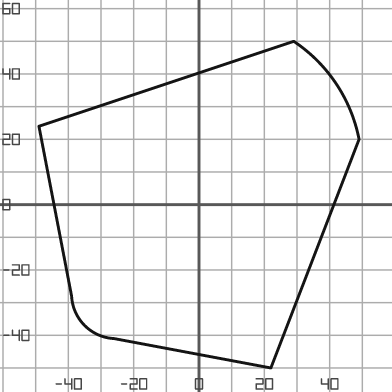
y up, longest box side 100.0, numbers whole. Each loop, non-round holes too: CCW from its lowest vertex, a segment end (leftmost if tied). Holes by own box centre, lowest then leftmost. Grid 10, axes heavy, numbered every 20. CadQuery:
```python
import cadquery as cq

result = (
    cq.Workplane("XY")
    .moveTo(22.0, -50.0)
    .lineTo(49.0, 20.0)
    .threePointArc((42.0, 37.0), (29.0, 50.0))
    .lineTo(-49.0, 24.0)
    .lineTo(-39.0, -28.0)
    .threePointArc((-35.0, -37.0), (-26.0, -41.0))
    .close()
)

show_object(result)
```